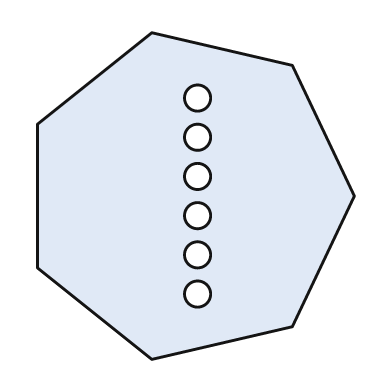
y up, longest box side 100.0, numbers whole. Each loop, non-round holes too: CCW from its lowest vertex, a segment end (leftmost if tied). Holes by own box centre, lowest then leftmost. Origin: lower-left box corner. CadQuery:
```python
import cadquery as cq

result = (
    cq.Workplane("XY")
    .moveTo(35.0, 0.0)
    .lineTo(78.0, 10.0)
    .lineTo(97.0, 50.0)
    .lineTo(78.0, 90.0)
    .lineTo(35.0, 100.0)
    .lineTo(0.0, 72.0)
    .lineTo(0.0, 28.0)
    .close()
    .moveTo(49.0, 20.0)
    .circle(4.0)
    .moveTo(49.0, 32.0)
    .circle(4.0)
    .moveTo(49.0, 44.0)
    .circle(4.0)
    .moveTo(49.0, 56.0)
    .circle(4.0)
    .moveTo(49.0, 68.0)
    .circle(4.0)
    .moveTo(49.0, 80.0)
    .circle(4.0)
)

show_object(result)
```